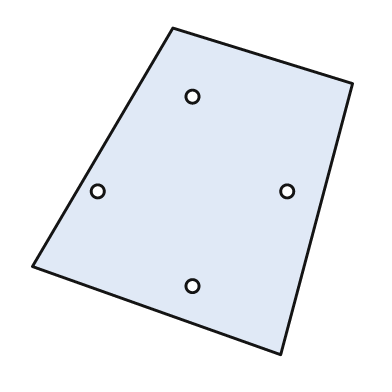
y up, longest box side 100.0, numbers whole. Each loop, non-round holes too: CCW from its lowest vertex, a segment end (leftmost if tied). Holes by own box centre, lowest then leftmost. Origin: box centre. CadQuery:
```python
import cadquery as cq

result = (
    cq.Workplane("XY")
    .moveTo(27.0, -50.0)
    .lineTo(49.0, 33.0)
    .lineTo(-6.0, 50.0)
    .lineTo(-49.0, -23.0)
    .close()
    .moveTo(0.0, -29.0)
    .circle(2.0)
    .moveTo(-29.0, 0.0)
    .circle(2.0)
    .moveTo(29.0, 0.0)
    .circle(2.0)
    .moveTo(0.0, 29.0)
    .circle(2.0)
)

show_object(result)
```